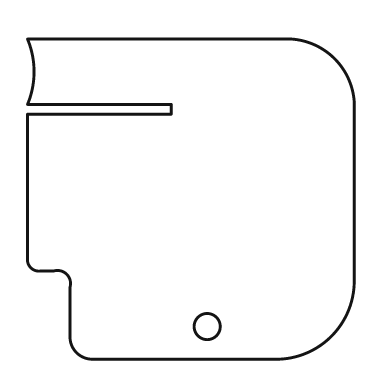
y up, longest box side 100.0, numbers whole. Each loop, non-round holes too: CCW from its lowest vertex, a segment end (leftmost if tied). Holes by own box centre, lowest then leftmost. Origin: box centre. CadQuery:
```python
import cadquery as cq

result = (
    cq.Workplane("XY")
    .moveTo(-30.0, -49.0)
    .lineTo(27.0, -49.0)
    .threePointArc((43.0, -42.0), (50.0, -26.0))
    .lineTo(50.0, 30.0)
    .threePointArc((44.0, 43.0), (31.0, 49.0))
    .lineTo(-50.0, 49.0)
    .threePointArc((-48.0, 39.0), (-50.0, 29.0))
    .lineTo(-6.0, 29.0)
    .lineTo(-6.0, 26.0)
    .lineTo(-50.0, 26.0)
    .lineTo(-50.0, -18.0)
    .threePointArc((-49.0, -21.0), (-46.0, -22.0))
    .lineTo(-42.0, -22.0)
    .threePointArc((-38.0, -23.0), (-37.0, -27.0))
    .lineTo(-37.0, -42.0)
    .threePointArc((-35.0, -47.0), (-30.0, -49.0))
    .close()
    .moveTo(5.0, -39.0)
    .circle(4.0)
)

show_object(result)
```